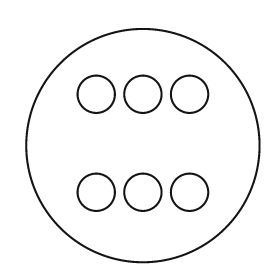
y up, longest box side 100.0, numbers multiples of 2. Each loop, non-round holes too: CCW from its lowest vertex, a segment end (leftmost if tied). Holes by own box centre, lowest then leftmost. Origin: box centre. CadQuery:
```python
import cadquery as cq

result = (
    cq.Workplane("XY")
    .moveTo(0.0, 0.0)
    .circle(50.0)
    .moveTo(-20.0, -20.0)
    .circle(8.0)
    .moveTo(0.0, -20.0)
    .circle(8.0)
    .moveTo(20.0, -20.0)
    .circle(8.0)
    .moveTo(-20.0, 22.0)
    .circle(8.0)
    .moveTo(0.0, 22.0)
    .circle(8.0)
    .moveTo(20.0, 22.0)
    .circle(8.0)
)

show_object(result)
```